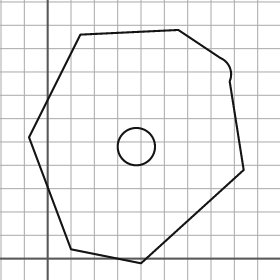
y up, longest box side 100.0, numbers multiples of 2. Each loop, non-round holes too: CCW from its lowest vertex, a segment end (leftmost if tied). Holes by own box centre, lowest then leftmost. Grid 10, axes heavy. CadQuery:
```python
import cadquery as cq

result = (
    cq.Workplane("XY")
    .moveTo(40.0, -2.0)
    .lineTo(84.0, 38.0)
    .lineTo(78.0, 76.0)
    .threePointArc((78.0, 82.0), (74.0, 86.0))
    .lineTo(56.0, 98.0)
    .lineTo(14.0, 96.0)
    .lineTo(-8.0, 52.0)
    .lineTo(10.0, 4.0)
    .close()
    .moveTo(38.0, 48.0)
    .circle(8.0)
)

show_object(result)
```